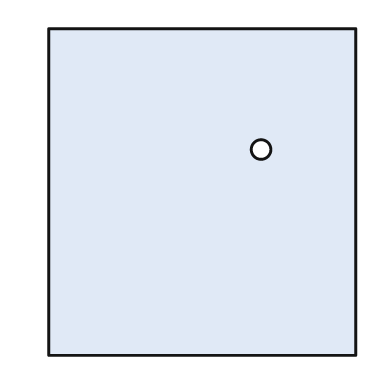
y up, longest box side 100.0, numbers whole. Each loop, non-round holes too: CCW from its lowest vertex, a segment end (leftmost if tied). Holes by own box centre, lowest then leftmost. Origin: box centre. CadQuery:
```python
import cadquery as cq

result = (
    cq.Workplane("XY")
    .moveTo(-47.0, -50.0)
    .lineTo(47.0, -50.0)
    .lineTo(47.0, 50.0)
    .lineTo(-47.0, 50.0)
    .close()
    .moveTo(18.0, 13.0)
    .circle(3.0)
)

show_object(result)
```